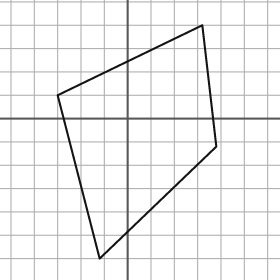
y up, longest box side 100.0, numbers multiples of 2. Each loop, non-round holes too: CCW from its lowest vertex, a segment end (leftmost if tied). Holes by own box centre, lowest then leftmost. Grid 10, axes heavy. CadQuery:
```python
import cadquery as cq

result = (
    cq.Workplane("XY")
    .moveTo(-12.0, -60.0)
    .lineTo(38.0, -12.0)
    .lineTo(32.0, 40.0)
    .lineTo(-30.0, 10.0)
    .close()
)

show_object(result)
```